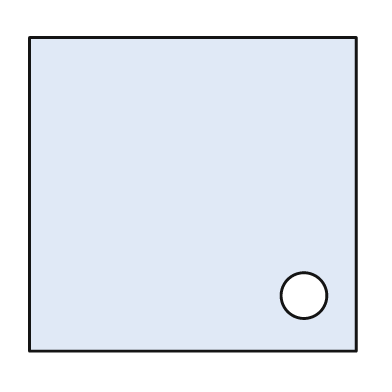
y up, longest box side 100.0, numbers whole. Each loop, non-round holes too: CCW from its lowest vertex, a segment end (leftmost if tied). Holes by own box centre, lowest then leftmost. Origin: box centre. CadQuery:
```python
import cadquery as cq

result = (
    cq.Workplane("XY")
    .moveTo(-50.0, -48.0)
    .lineTo(50.0, -48.0)
    .lineTo(50.0, 48.0)
    .lineTo(-50.0, 48.0)
    .close()
    .moveTo(34.0, -31.0)
    .circle(7.0)
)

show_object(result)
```